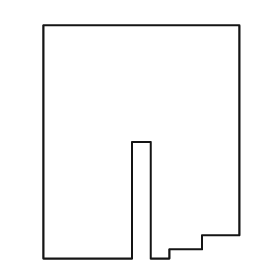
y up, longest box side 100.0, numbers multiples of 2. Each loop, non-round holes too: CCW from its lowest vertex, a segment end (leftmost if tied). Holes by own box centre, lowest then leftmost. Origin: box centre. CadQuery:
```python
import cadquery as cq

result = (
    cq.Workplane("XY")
    .moveTo(-42.0, -50.0)
    .lineTo(-4.0, -50.0)
    .lineTo(-4.0, 0.0)
    .lineTo(4.0, 0.0)
    .lineTo(4.0, -50.0)
    .lineTo(12.0, -50.0)
    .lineTo(12.0, -46.0)
    .lineTo(26.0, -46.0)
    .lineTo(26.0, -40.0)
    .lineTo(42.0, -40.0)
    .lineTo(42.0, 50.0)
    .lineTo(-42.0, 50.0)
    .close()
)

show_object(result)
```